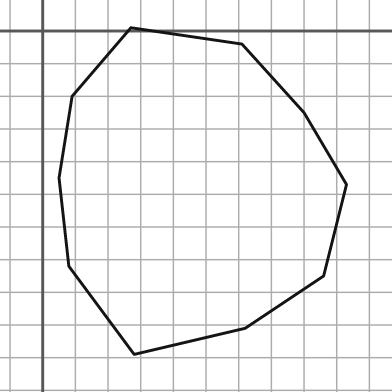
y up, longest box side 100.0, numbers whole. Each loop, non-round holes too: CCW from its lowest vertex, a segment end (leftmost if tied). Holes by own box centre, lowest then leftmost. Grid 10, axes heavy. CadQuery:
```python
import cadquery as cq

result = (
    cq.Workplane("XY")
    .moveTo(28.0, -99.0)
    .lineTo(62.0, -91.0)
    .lineTo(86.0, -75.0)
    .lineTo(93.0, -47.0)
    .lineTo(80.0, -25.0)
    .lineTo(61.0, -4.0)
    .lineTo(27.0, 1.0)
    .lineTo(9.0, -20.0)
    .lineTo(5.0, -45.0)
    .lineTo(8.0, -72.0)
    .close()
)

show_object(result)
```